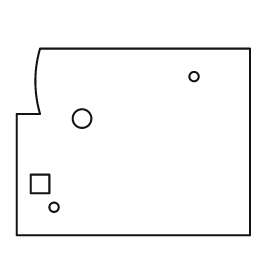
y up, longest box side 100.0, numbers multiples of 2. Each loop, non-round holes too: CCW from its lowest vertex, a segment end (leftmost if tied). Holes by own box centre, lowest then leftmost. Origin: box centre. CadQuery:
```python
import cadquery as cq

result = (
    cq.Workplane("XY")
    .moveTo(-50.0, -40.0)
    .lineTo(50.0, -40.0)
    .lineTo(50.0, 40.0)
    .lineTo(-40.0, 40.0)
    .threePointArc((-42.0, 26.0), (-40.0, 12.0))
    .lineTo(-50.0, 12.0)
    .close()
    .moveTo(-34.0, -28.0)
    .circle(2.0)
    .moveTo(-44.0, -22.0)
    .lineTo(-36.0, -22.0)
    .lineTo(-36.0, -14.0)
    .lineTo(-44.0, -14.0)
    .close()
    .moveTo(-22.0, 10.0)
    .circle(4.0)
    .moveTo(26.0, 28.0)
    .circle(2.0)
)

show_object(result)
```